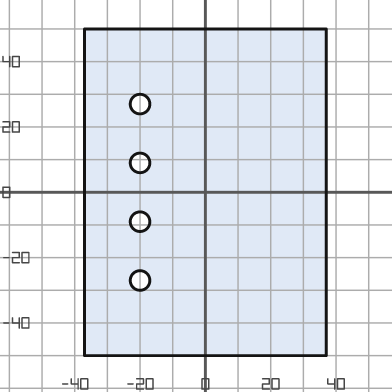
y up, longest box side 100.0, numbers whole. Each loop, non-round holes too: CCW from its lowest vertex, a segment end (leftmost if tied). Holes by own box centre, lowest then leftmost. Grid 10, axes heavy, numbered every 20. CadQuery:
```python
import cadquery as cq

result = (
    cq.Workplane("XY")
    .moveTo(-37.0, -50.0)
    .lineTo(37.0, -50.0)
    .lineTo(37.0, 50.0)
    .lineTo(-37.0, 50.0)
    .close()
    .moveTo(-20.0, -27.0)
    .circle(3.0)
    .moveTo(-20.0, -9.0)
    .circle(3.0)
    .moveTo(-20.0, 9.0)
    .circle(3.0)
    .moveTo(-20.0, 27.0)
    .circle(3.0)
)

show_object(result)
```